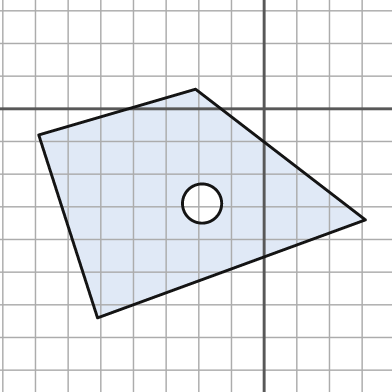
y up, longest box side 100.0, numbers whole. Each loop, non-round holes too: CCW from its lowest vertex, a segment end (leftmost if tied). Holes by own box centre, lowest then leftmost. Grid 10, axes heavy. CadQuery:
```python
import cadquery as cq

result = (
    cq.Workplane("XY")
    .moveTo(-51.0, -64.0)
    .lineTo(31.0, -34.0)
    .lineTo(-21.0, 6.0)
    .lineTo(-69.0, -8.0)
    .close()
    .moveTo(-19.0, -29.0)
    .circle(6.0)
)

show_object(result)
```